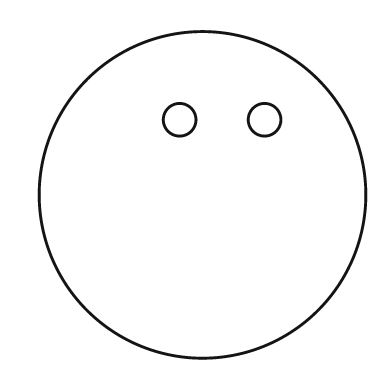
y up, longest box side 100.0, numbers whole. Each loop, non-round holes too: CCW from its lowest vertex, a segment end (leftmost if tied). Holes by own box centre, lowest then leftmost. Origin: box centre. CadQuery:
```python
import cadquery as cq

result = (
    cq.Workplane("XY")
    .moveTo(0.0, 0.0)
    .circle(50.0)
    .moveTo(-7.0, 23.0)
    .circle(5.0)
    .moveTo(19.0, 23.0)
    .circle(5.0)
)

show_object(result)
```